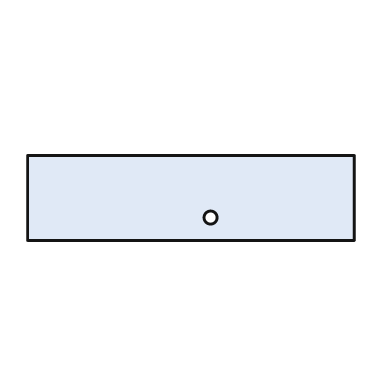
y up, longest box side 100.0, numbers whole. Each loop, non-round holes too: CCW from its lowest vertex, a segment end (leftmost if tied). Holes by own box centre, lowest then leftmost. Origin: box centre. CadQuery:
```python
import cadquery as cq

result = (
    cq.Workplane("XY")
    .moveTo(-50.0, -13.0)
    .lineTo(50.0, -13.0)
    .lineTo(50.0, 13.0)
    .lineTo(-50.0, 13.0)
    .close()
    .moveTo(6.0, -6.0)
    .circle(2.0)
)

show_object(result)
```